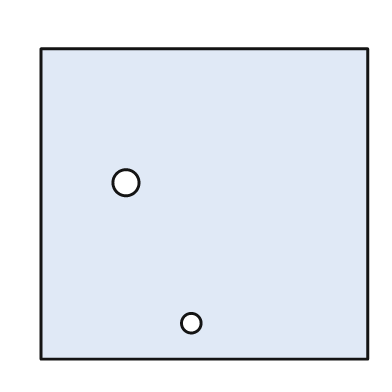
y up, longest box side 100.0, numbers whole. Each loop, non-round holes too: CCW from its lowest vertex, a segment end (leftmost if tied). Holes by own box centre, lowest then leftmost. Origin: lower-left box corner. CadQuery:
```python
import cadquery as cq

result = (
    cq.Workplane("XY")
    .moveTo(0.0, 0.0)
    .lineTo(100.0, 0.0)
    .lineTo(100.0, 95.0)
    .lineTo(0.0, 95.0)
    .close()
    .moveTo(46.0, 11.0)
    .circle(3.0)
    .moveTo(26.0, 54.0)
    .circle(4.0)
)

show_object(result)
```